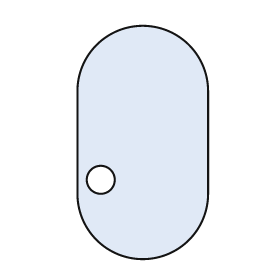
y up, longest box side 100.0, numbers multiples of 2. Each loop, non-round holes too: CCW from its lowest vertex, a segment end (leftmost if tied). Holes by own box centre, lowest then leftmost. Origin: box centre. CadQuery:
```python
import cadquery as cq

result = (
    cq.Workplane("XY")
    .moveTo(-28.0, -22.0)
    .threePointArc((0.0, -50.0), (28.0, -22.0))
    .lineTo(28.0, 22.0)
    .threePointArc((0.0, 50.0), (-28.0, 22.0))
    .close()
    .moveTo(-18.0, -16.0)
    .circle(6.0)
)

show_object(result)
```